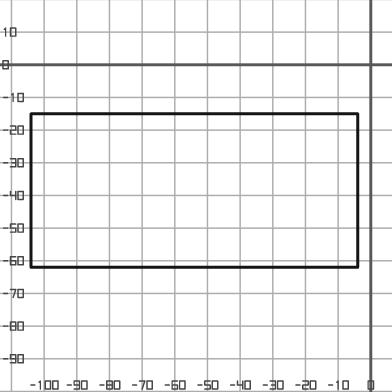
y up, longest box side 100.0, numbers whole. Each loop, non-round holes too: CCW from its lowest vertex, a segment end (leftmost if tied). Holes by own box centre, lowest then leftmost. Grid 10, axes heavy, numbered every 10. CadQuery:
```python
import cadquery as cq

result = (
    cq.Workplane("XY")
    .moveTo(-104.0, -62.0)
    .lineTo(-4.0, -62.0)
    .lineTo(-4.0, -15.0)
    .lineTo(-104.0, -15.0)
    .close()
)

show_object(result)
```